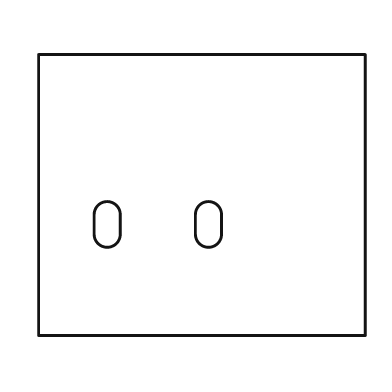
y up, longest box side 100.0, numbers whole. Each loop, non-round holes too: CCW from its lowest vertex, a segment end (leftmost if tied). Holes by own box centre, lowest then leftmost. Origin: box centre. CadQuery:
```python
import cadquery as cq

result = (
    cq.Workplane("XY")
    .moveTo(-50.0, -43.0)
    .lineTo(50.0, -43.0)
    .lineTo(50.0, 43.0)
    .lineTo(-50.0, 43.0)
    .close()
    .moveTo(-33.0, -12.0)
    .threePointArc((-29.0, -16.0), (-25.0, -12.0))
    .lineTo(-25.0, -6.0)
    .threePointArc((-29.0, -2.0), (-33.0, -6.0))
    .close()
    .moveTo(-2.0, -12.0)
    .threePointArc((2.0, -16.0), (6.0, -12.0))
    .lineTo(6.0, -6.0)
    .threePointArc((2.0, -2.0), (-2.0, -6.0))
    .close()
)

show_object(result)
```